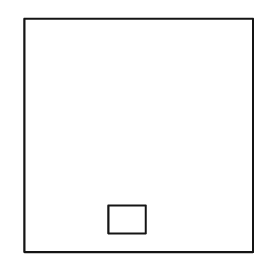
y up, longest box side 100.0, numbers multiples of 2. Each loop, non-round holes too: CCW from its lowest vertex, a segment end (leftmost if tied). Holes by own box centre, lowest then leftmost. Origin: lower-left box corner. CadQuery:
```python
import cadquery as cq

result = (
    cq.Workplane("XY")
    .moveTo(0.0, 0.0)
    .lineTo(98.0, 0.0)
    .lineTo(98.0, 100.0)
    .lineTo(0.0, 100.0)
    .close()
    .moveTo(36.0, 8.0)
    .lineTo(52.0, 8.0)
    .lineTo(52.0, 20.0)
    .lineTo(36.0, 20.0)
    .close()
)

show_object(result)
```